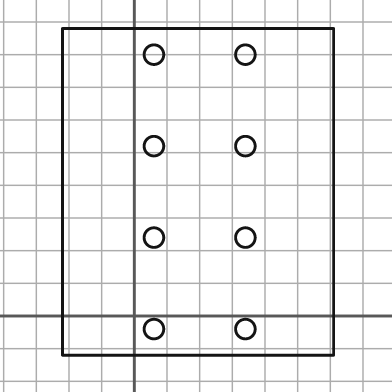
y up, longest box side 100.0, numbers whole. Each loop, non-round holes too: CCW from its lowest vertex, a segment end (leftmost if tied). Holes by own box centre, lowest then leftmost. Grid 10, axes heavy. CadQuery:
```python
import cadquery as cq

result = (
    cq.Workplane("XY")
    .moveTo(-22.0, -12.0)
    .lineTo(61.0, -12.0)
    .lineTo(61.0, 88.0)
    .lineTo(-22.0, 88.0)
    .close()
    .moveTo(6.0, -4.0)
    .circle(3.0)
    .moveTo(34.0, -4.0)
    .circle(3.0)
    .moveTo(6.0, 24.0)
    .circle(3.0)
    .moveTo(34.0, 24.0)
    .circle(3.0)
    .moveTo(6.0, 52.0)
    .circle(3.0)
    .moveTo(34.0, 52.0)
    .circle(3.0)
    .moveTo(6.0, 80.0)
    .circle(3.0)
    .moveTo(34.0, 80.0)
    .circle(3.0)
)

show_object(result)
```